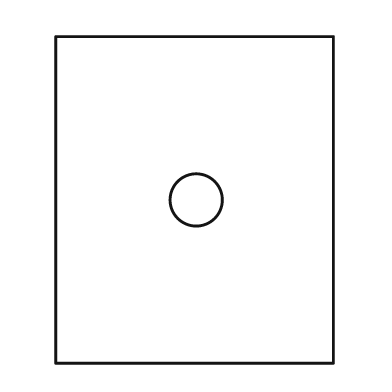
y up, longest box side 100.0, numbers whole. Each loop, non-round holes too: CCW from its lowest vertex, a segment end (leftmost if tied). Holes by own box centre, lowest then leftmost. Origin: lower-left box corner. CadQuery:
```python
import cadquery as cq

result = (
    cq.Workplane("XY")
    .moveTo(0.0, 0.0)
    .lineTo(85.0, 0.0)
    .lineTo(85.0, 100.0)
    .lineTo(0.0, 100.0)
    .close()
    .moveTo(43.0, 50.0)
    .circle(8.0)
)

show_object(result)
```